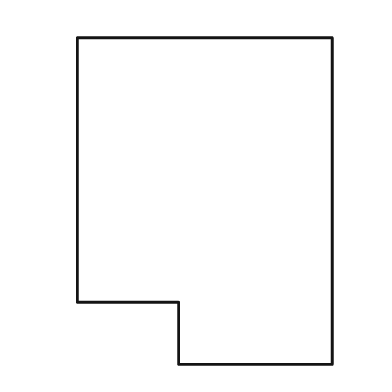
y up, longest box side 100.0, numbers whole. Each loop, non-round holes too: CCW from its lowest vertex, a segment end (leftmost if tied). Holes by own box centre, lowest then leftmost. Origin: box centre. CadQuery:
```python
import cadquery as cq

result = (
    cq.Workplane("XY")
    .moveTo(-8.0, -50.0)
    .lineTo(39.0, -50.0)
    .lineTo(39.0, 50.0)
    .lineTo(-39.0, 50.0)
    .lineTo(-39.0, -31.0)
    .lineTo(-8.0, -31.0)
    .close()
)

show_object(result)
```